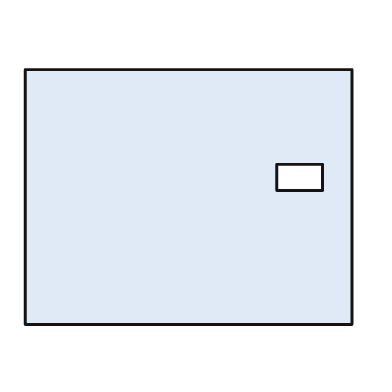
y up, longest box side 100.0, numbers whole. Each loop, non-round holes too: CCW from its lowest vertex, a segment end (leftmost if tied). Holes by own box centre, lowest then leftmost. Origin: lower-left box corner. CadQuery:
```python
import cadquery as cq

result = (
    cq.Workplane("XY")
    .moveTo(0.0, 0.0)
    .lineTo(100.0, 0.0)
    .lineTo(100.0, 78.0)
    .lineTo(0.0, 78.0)
    .close()
    .moveTo(77.0, 41.0)
    .lineTo(91.0, 41.0)
    .lineTo(91.0, 49.0)
    .lineTo(77.0, 49.0)
    .close()
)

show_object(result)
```